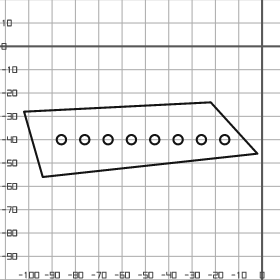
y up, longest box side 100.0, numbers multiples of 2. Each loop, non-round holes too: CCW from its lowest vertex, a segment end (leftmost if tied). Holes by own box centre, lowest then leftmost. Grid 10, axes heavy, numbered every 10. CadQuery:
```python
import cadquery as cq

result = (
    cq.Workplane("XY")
    .moveTo(-94.0, -56.0)
    .lineTo(-2.0, -46.0)
    .lineTo(-22.0, -24.0)
    .lineTo(-102.0, -28.0)
    .close()
    .moveTo(-86.0, -40.0)
    .circle(2.0)
    .moveTo(-76.0, -40.0)
    .circle(2.0)
    .moveTo(-66.0, -40.0)
    .circle(2.0)
    .moveTo(-56.0, -40.0)
    .circle(2.0)
    .moveTo(-46.0, -40.0)
    .circle(2.0)
    .moveTo(-36.0, -40.0)
    .circle(2.0)
    .moveTo(-26.0, -40.0)
    .circle(2.0)
    .moveTo(-16.0, -40.0)
    .circle(2.0)
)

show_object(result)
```